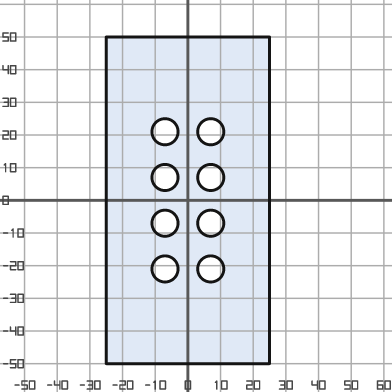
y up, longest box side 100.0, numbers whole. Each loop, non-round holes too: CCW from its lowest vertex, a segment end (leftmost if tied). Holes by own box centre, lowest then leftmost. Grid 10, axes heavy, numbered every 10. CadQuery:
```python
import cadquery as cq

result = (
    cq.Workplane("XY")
    .moveTo(-25.0, -50.0)
    .lineTo(25.0, -50.0)
    .lineTo(25.0, 50.0)
    .lineTo(-25.0, 50.0)
    .close()
    .moveTo(-7.0, -21.0)
    .circle(4.0)
    .moveTo(7.0, -21.0)
    .circle(4.0)
    .moveTo(-7.0, -7.0)
    .circle(4.0)
    .moveTo(7.0, -7.0)
    .circle(4.0)
    .moveTo(-7.0, 7.0)
    .circle(4.0)
    .moveTo(7.0, 7.0)
    .circle(4.0)
    .moveTo(-7.0, 21.0)
    .circle(4.0)
    .moveTo(7.0, 21.0)
    .circle(4.0)
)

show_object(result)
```